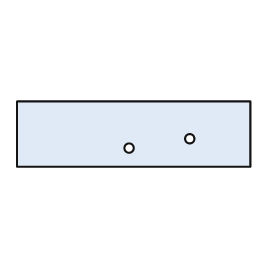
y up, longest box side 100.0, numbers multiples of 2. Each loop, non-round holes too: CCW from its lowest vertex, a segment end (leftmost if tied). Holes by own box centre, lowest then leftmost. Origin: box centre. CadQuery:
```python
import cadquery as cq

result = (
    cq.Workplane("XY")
    .moveTo(-50.0, -14.0)
    .lineTo(50.0, -14.0)
    .lineTo(50.0, 14.0)
    .lineTo(-50.0, 14.0)
    .close()
    .moveTo(-2.0, -6.0)
    .circle(2.0)
    .moveTo(24.0, -2.0)
    .circle(2.0)
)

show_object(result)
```